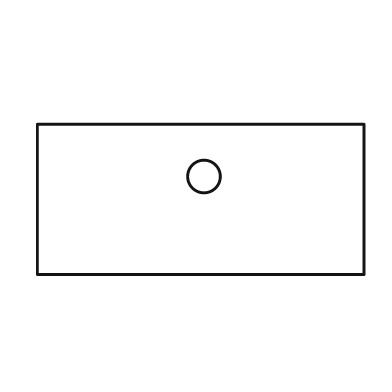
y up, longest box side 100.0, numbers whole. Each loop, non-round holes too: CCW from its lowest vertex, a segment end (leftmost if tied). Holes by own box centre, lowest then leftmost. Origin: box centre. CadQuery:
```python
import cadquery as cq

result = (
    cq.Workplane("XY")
    .moveTo(-50.0, -23.0)
    .lineTo(50.0, -23.0)
    .lineTo(50.0, 23.0)
    .lineTo(-50.0, 23.0)
    .close()
    .moveTo(1.0, 7.0)
    .circle(5.0)
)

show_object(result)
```